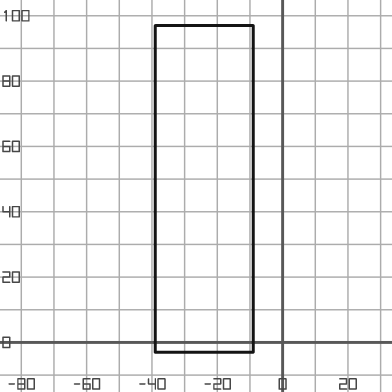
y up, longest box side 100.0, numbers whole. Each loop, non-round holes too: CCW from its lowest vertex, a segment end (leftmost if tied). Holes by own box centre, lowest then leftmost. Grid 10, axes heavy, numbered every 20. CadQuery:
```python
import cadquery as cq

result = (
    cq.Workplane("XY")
    .moveTo(-39.0, -3.0)
    .lineTo(-9.0, -3.0)
    .lineTo(-9.0, 97.0)
    .lineTo(-39.0, 97.0)
    .close()
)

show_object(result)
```